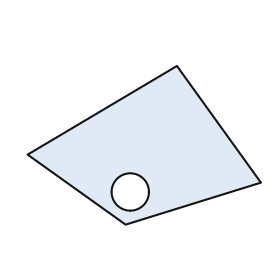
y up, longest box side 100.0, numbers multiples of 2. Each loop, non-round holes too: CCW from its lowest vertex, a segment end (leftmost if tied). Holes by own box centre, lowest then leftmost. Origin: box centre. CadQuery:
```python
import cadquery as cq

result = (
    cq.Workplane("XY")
    .moveTo(-8.0, -34.0)
    .lineTo(50.0, -16.0)
    .lineTo(14.0, 34.0)
    .lineTo(-50.0, -4.0)
    .close()
    .moveTo(-6.0, -20.0)
    .circle(8.0)
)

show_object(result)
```